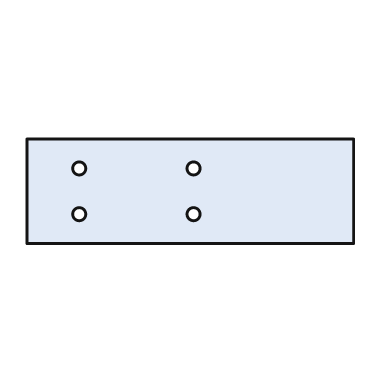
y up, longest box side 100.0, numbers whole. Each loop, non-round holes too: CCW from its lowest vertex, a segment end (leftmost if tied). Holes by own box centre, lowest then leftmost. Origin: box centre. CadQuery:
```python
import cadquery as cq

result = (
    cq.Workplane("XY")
    .moveTo(-50.0, -16.0)
    .lineTo(50.0, -16.0)
    .lineTo(50.0, 16.0)
    .lineTo(-50.0, 16.0)
    .close()
    .moveTo(-34.0, -7.0)
    .circle(2.0)
    .moveTo(1.0, -7.0)
    .circle(2.0)
    .moveTo(-34.0, 7.0)
    .circle(2.0)
    .moveTo(1.0, 7.0)
    .circle(2.0)
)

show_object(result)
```